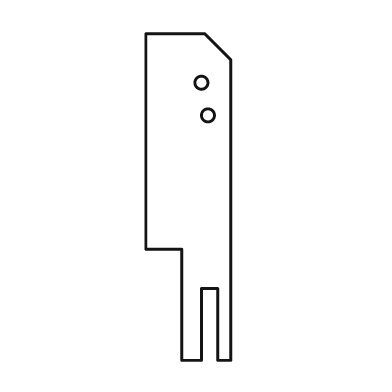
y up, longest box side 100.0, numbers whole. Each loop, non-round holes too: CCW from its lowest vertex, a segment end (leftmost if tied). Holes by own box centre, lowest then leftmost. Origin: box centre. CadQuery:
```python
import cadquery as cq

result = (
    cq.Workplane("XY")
    .moveTo(-2.0, -50.0)
    .lineTo(4.0, -50.0)
    .lineTo(4.0, -28.0)
    .lineTo(9.0, -28.0)
    .lineTo(9.0, -50.0)
    .lineTo(13.0, -50.0)
    .lineTo(13.0, 42.0)
    .lineTo(5.0, 50.0)
    .lineTo(-13.0, 50.0)
    .lineTo(-13.0, -16.0)
    .lineTo(-2.0, -16.0)
    .close()
    .moveTo(6.0, 25.0)
    .circle(2.0)
    .moveTo(4.0, 35.0)
    .circle(2.0)
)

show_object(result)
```